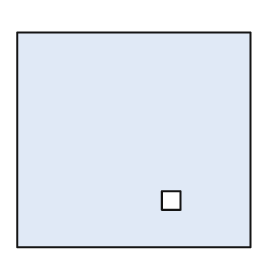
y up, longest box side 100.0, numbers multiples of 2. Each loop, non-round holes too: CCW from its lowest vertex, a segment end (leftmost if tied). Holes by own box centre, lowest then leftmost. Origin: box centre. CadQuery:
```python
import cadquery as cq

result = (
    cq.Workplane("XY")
    .moveTo(-50.0, -46.0)
    .lineTo(50.0, -46.0)
    .lineTo(50.0, 46.0)
    .lineTo(-50.0, 46.0)
    .close()
    .moveTo(12.0, -30.0)
    .lineTo(20.0, -30.0)
    .lineTo(20.0, -22.0)
    .lineTo(12.0, -22.0)
    .close()
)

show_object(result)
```